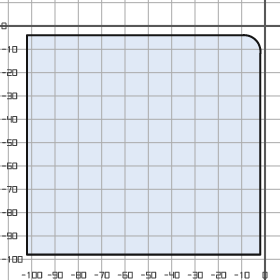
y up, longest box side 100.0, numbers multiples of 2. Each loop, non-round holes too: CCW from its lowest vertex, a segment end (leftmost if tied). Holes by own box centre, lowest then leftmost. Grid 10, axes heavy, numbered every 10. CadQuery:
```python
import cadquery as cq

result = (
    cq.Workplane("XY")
    .moveTo(-102.0, -98.0)
    .lineTo(-2.0, -98.0)
    .lineTo(-2.0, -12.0)
    .threePointArc((-4.0, -6.0), (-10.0, -4.0))
    .lineTo(-102.0, -4.0)
    .close()
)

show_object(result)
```